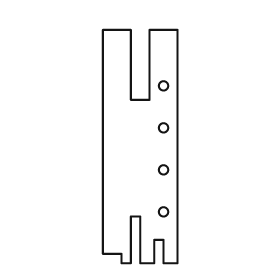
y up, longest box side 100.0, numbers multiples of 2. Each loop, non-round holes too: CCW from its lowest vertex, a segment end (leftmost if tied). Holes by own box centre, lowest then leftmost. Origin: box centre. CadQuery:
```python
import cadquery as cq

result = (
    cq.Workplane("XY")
    .moveTo(-8.0, -50.0)
    .lineTo(-4.0, -50.0)
    .lineTo(-4.0, -30.0)
    .lineTo(0.0, -30.0)
    .lineTo(0.0, -50.0)
    .lineTo(6.0, -50.0)
    .lineTo(6.0, -40.0)
    .lineTo(10.0, -40.0)
    .lineTo(10.0, -50.0)
    .lineTo(16.0, -50.0)
    .lineTo(16.0, 50.0)
    .lineTo(4.0, 50.0)
    .lineTo(4.0, 20.0)
    .lineTo(-4.0, 20.0)
    .lineTo(-4.0, 50.0)
    .lineTo(-16.0, 50.0)
    .lineTo(-16.0, -46.0)
    .lineTo(-8.0, -46.0)
    .close()
    .moveTo(10.0, -28.0)
    .circle(2.0)
    .moveTo(10.0, -10.0)
    .circle(2.0)
    .moveTo(10.0, 8.0)
    .circle(2.0)
    .moveTo(10.0, 26.0)
    .circle(2.0)
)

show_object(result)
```